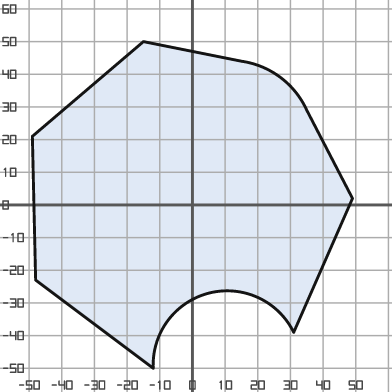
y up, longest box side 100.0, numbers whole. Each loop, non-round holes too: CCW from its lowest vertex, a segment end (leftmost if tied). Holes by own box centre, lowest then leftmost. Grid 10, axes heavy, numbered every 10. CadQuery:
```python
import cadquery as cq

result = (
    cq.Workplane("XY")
    .moveTo(-12.0, -50.0)
    .threePointArc((5.0, -27.0), (31.0, -39.0))
    .lineTo(49.0, 2.0)
    .lineTo(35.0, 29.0)
    .threePointArc((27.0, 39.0), (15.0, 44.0))
    .lineTo(-15.0, 50.0)
    .lineTo(-49.0, 21.0)
    .lineTo(-48.0, -23.0)
    .close()
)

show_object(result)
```